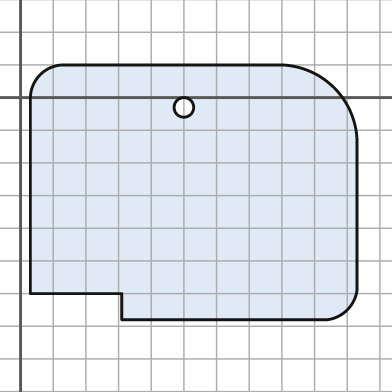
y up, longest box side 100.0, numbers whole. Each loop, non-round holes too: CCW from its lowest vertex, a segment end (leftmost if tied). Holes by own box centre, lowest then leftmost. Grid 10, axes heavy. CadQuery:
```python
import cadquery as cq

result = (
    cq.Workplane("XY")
    .moveTo(31.0, -68.0)
    .lineTo(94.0, -68.0)
    .threePointArc((100.0, -65.0), (103.0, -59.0))
    .lineTo(103.0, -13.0)
    .threePointArc((96.0, 3.0), (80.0, 10.0))
    .lineTo(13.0, 10.0)
    .threePointArc((6.0, 7.0), (3.0, 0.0))
    .lineTo(3.0, -60.0)
    .lineTo(31.0, -60.0)
    .close()
    .moveTo(50.0, -3.0)
    .circle(3.0)
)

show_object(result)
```